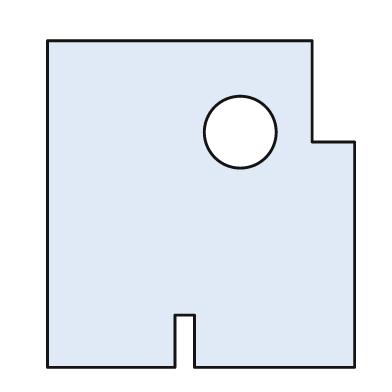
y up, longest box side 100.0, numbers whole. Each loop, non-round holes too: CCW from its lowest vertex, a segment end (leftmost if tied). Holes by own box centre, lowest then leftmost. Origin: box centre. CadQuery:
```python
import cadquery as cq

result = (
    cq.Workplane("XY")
    .moveTo(-47.0, -50.0)
    .lineTo(-8.0, -50.0)
    .lineTo(-8.0, -34.0)
    .lineTo(-2.0, -34.0)
    .lineTo(-2.0, -50.0)
    .lineTo(47.0, -50.0)
    .lineTo(47.0, 19.0)
    .lineTo(34.0, 19.0)
    .lineTo(34.0, 50.0)
    .lineTo(-47.0, 50.0)
    .close()
    .moveTo(12.0, 22.0)
    .circle(11.0)
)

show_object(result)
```